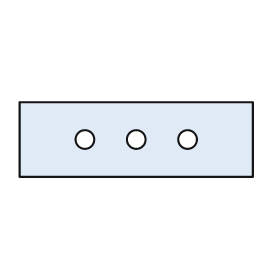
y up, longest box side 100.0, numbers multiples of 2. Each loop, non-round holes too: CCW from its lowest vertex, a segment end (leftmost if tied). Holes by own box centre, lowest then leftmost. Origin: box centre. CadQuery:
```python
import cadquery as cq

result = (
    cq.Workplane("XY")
    .moveTo(-50.0, -16.0)
    .lineTo(50.0, -16.0)
    .lineTo(50.0, 16.0)
    .lineTo(-50.0, 16.0)
    .close()
    .moveTo(-22.0, 0.0)
    .circle(4.0)
    .moveTo(0.0, 0.0)
    .circle(4.0)
    .moveTo(22.0, 0.0)
    .circle(4.0)
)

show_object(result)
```